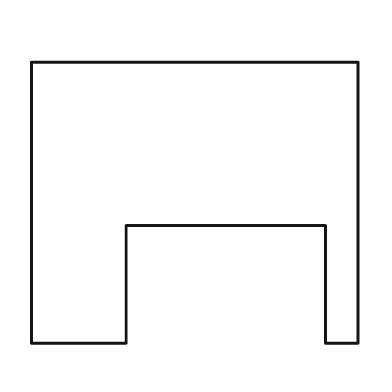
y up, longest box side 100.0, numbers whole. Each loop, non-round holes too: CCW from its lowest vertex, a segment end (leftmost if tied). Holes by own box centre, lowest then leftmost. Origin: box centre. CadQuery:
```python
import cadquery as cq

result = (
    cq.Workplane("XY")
    .moveTo(-50.0, -43.0)
    .lineTo(-21.0, -43.0)
    .lineTo(-21.0, -7.0)
    .lineTo(40.0, -7.0)
    .lineTo(40.0, -43.0)
    .lineTo(50.0, -43.0)
    .lineTo(50.0, 43.0)
    .lineTo(-50.0, 43.0)
    .close()
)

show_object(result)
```